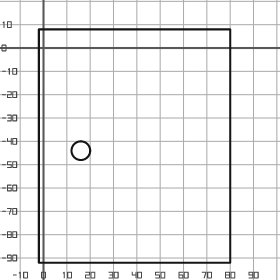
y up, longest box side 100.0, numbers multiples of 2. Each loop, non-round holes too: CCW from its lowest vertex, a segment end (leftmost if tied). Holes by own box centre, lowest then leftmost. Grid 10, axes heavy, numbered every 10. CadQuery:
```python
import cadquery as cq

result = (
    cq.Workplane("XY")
    .moveTo(-2.0, -92.0)
    .lineTo(80.0, -92.0)
    .lineTo(80.0, 8.0)
    .lineTo(-2.0, 8.0)
    .close()
    .moveTo(16.0, -44.0)
    .circle(4.0)
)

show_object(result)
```